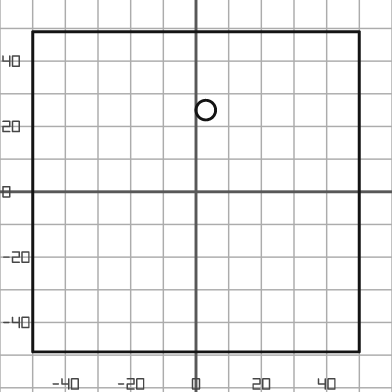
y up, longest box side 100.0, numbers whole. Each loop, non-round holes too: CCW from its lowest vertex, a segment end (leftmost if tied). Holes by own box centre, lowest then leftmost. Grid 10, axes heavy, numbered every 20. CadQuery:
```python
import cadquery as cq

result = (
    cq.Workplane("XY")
    .moveTo(-50.0, -49.0)
    .lineTo(50.0, -49.0)
    .lineTo(50.0, 49.0)
    .lineTo(-50.0, 49.0)
    .close()
    .moveTo(3.0, 25.0)
    .circle(3.0)
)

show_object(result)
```